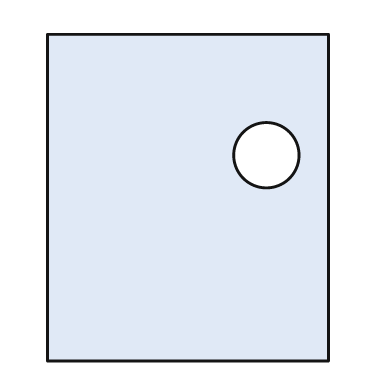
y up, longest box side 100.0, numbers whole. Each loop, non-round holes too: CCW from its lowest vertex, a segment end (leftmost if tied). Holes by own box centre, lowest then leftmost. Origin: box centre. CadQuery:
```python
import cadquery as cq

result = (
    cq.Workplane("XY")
    .moveTo(-43.0, -50.0)
    .lineTo(43.0, -50.0)
    .lineTo(43.0, 50.0)
    .lineTo(-43.0, 50.0)
    .close()
    .moveTo(24.0, 13.0)
    .circle(10.0)
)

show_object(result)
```